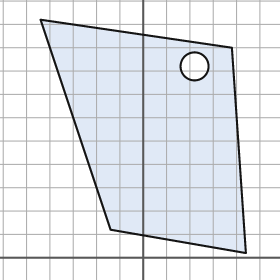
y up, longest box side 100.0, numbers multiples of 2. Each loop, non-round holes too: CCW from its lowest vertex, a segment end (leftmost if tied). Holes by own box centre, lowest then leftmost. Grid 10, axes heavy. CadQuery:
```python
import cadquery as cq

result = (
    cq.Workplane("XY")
    .moveTo(44.0, 2.0)
    .lineTo(38.0, 90.0)
    .lineTo(-44.0, 102.0)
    .lineTo(-14.0, 12.0)
    .close()
    .moveTo(22.0, 82.0)
    .circle(6.0)
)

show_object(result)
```